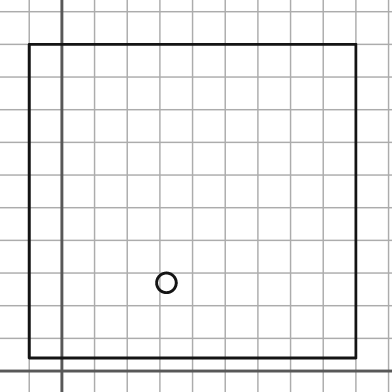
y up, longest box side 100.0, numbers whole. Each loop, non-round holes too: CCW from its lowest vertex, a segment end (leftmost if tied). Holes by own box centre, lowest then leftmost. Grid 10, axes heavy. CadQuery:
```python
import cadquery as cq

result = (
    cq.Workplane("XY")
    .moveTo(-10.0, 4.0)
    .lineTo(90.0, 4.0)
    .lineTo(90.0, 100.0)
    .lineTo(-10.0, 100.0)
    .close()
    .moveTo(32.0, 27.0)
    .circle(3.0)
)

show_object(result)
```